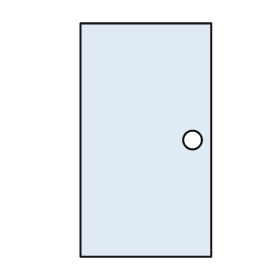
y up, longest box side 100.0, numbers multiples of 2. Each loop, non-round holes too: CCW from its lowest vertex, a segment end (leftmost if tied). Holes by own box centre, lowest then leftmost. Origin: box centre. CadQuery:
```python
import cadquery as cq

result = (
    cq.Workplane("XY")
    .moveTo(-28.0, -50.0)
    .lineTo(28.0, -50.0)
    .lineTo(28.0, 50.0)
    .lineTo(-28.0, 50.0)
    .close()
    .moveTo(20.0, 0.0)
    .circle(4.0)
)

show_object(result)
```